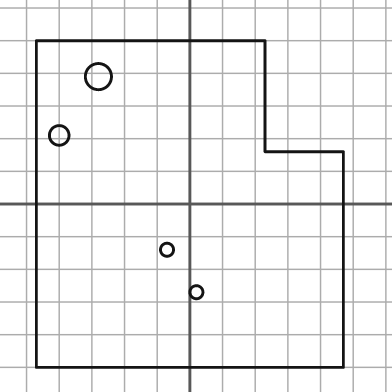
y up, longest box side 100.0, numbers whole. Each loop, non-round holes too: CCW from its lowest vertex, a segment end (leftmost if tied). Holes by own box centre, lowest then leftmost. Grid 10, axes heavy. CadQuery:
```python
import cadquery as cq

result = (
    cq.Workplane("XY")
    .moveTo(-47.0, -50.0)
    .lineTo(47.0, -50.0)
    .lineTo(47.0, 16.0)
    .lineTo(23.0, 16.0)
    .lineTo(23.0, 50.0)
    .lineTo(-47.0, 50.0)
    .close()
    .moveTo(2.0, -27.0)
    .circle(2.0)
    .moveTo(-7.0, -14.0)
    .circle(2.0)
    .moveTo(-40.0, 21.0)
    .circle(3.0)
    .moveTo(-28.0, 39.0)
    .circle(4.0)
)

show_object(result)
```